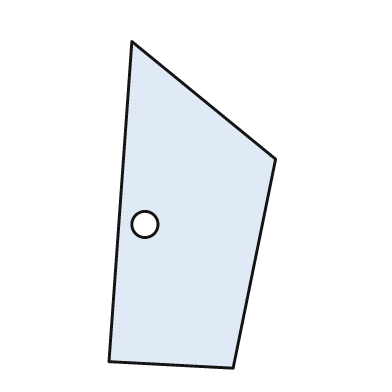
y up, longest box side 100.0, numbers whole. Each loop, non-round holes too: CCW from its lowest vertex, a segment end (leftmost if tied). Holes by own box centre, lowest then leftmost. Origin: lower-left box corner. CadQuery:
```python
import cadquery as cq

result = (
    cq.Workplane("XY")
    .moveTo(38.0, 0.0)
    .lineTo(51.0, 64.0)
    .lineTo(7.0, 100.0)
    .lineTo(0.0, 2.0)
    .close()
    .moveTo(11.0, 44.0)
    .circle(4.0)
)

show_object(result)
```